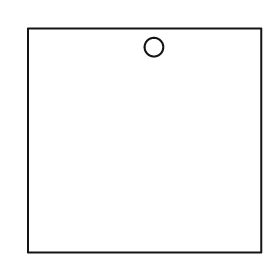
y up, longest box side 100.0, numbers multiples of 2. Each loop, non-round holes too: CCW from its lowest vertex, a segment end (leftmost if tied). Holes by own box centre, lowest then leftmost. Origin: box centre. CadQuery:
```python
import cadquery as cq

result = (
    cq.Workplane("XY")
    .moveTo(-50.0, -48.0)
    .lineTo(50.0, -48.0)
    .lineTo(50.0, 48.0)
    .lineTo(-50.0, 48.0)
    .close()
    .moveTo(4.0, 40.0)
    .circle(4.0)
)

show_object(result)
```